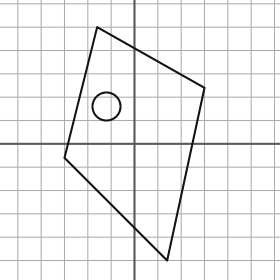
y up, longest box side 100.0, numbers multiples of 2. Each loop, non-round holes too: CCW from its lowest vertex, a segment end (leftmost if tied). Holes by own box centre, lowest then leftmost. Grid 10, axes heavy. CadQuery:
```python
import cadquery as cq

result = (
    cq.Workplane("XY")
    .moveTo(14.0, -50.0)
    .lineTo(30.0, 24.0)
    .lineTo(-16.0, 50.0)
    .lineTo(-30.0, -6.0)
    .close()
    .moveTo(-12.0, 16.0)
    .circle(6.0)
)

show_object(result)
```